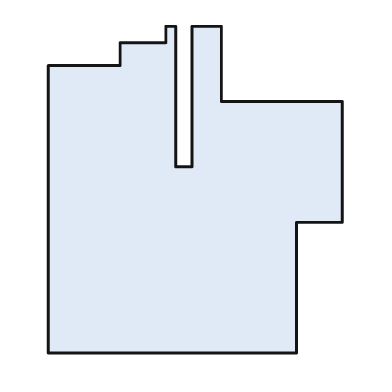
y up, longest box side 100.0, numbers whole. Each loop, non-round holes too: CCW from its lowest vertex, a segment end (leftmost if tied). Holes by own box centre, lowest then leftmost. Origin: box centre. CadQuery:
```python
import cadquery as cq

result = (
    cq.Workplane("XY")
    .moveTo(-45.0, -50.0)
    .lineTo(31.0, -50.0)
    .lineTo(31.0, -10.0)
    .lineTo(45.0, -10.0)
    .lineTo(45.0, 27.0)
    .lineTo(8.0, 27.0)
    .lineTo(8.0, 50.0)
    .lineTo(-1.0, 50.0)
    .lineTo(-1.0, 7.0)
    .lineTo(-6.0, 7.0)
    .lineTo(-6.0, 50.0)
    .lineTo(-9.0, 50.0)
    .lineTo(-9.0, 45.0)
    .lineTo(-23.0, 45.0)
    .lineTo(-23.0, 38.0)
    .lineTo(-45.0, 38.0)
    .close()
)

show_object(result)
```